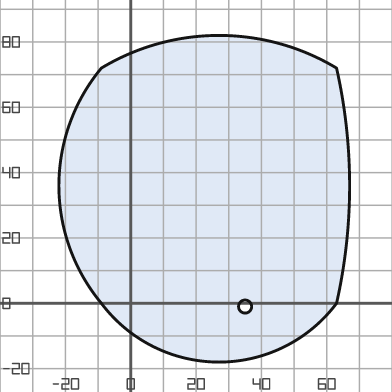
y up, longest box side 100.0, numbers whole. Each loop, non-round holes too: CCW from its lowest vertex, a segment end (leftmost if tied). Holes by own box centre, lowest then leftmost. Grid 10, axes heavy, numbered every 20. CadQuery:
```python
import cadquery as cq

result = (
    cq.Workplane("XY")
    .moveTo(-9.0, 0.0)
    .threePointArc((27.0, -18.0), (63.0, 0.0))
    .threePointArc((67.0, 36.0), (63.0, 72.0))
    .threePointArc((27.0, 82.0), (-9.0, 72.0))
    .threePointArc((-22.0, 36.0), (-9.0, 0.0))
    .close()
    .moveTo(35.0, -1.0)
    .circle(2.0)
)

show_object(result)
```